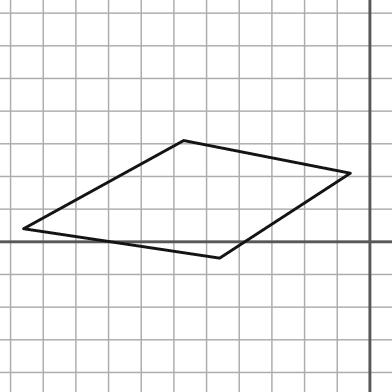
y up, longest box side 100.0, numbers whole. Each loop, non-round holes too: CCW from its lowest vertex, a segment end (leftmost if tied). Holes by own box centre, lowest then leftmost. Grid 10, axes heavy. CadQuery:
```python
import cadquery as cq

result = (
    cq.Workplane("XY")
    .moveTo(-46.0, -5.0)
    .lineTo(-6.0, 21.0)
    .lineTo(-57.0, 31.0)
    .lineTo(-106.0, 4.0)
    .close()
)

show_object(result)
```